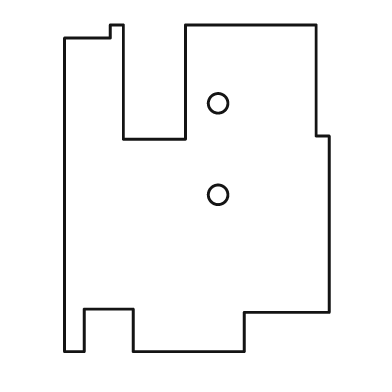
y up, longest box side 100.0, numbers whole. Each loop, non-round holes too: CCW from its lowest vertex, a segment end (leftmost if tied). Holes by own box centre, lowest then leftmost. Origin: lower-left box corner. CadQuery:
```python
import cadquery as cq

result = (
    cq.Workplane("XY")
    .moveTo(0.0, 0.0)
    .lineTo(6.0, 0.0)
    .lineTo(6.0, 13.0)
    .lineTo(21.0, 13.0)
    .lineTo(21.0, 0.0)
    .lineTo(55.0, 0.0)
    .lineTo(55.0, 12.0)
    .lineTo(81.0, 12.0)
    .lineTo(81.0, 66.0)
    .lineTo(77.0, 66.0)
    .lineTo(77.0, 100.0)
    .lineTo(37.0, 100.0)
    .lineTo(37.0, 65.0)
    .lineTo(18.0, 65.0)
    .lineTo(18.0, 100.0)
    .lineTo(14.0, 100.0)
    .lineTo(14.0, 96.0)
    .lineTo(0.0, 96.0)
    .close()
    .moveTo(47.0, 48.0)
    .circle(3.0)
    .moveTo(47.0, 76.0)
    .circle(3.0)
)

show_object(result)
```